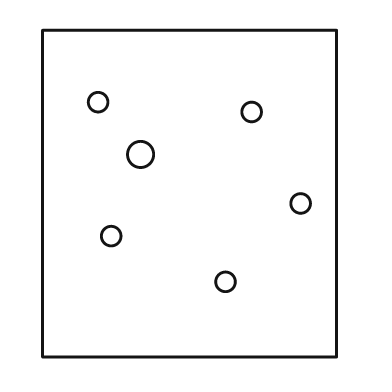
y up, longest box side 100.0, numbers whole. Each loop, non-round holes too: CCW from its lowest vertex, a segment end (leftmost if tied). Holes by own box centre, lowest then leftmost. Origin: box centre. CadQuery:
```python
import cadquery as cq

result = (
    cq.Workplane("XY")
    .moveTo(-45.0, -50.0)
    .lineTo(45.0, -50.0)
    .lineTo(45.0, 50.0)
    .lineTo(-45.0, 50.0)
    .close()
    .moveTo(11.0, -27.0)
    .circle(3.0)
    .moveTo(-24.0, -13.0)
    .circle(3.0)
    .moveTo(34.0, -3.0)
    .circle(3.0)
    .moveTo(-15.0, 12.0)
    .circle(4.0)
    .moveTo(19.0, 25.0)
    .circle(3.0)
    .moveTo(-28.0, 28.0)
    .circle(3.0)
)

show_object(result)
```